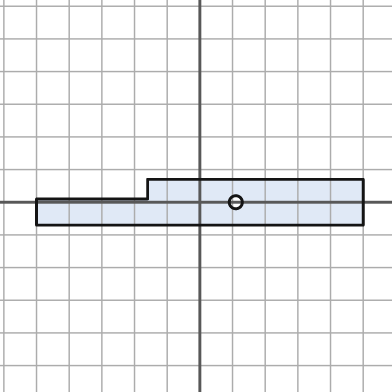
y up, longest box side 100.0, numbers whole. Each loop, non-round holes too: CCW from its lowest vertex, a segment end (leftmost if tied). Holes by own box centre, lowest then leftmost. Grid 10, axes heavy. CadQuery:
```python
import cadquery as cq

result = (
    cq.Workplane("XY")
    .moveTo(-50.0, -7.0)
    .lineTo(50.0, -7.0)
    .lineTo(50.0, 7.0)
    .lineTo(-16.0, 7.0)
    .lineTo(-16.0, 1.0)
    .lineTo(-50.0, 1.0)
    .close()
    .moveTo(11.0, 0.0)
    .circle(2.0)
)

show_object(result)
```